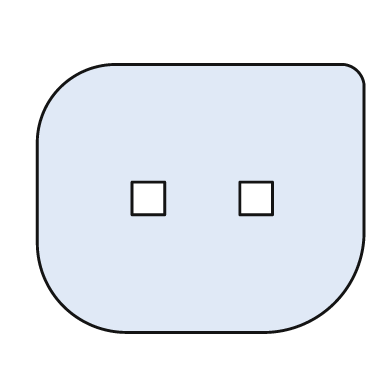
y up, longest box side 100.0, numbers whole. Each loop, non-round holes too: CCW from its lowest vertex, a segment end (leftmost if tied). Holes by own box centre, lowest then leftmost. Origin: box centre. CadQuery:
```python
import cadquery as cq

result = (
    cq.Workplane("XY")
    .moveTo(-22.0, -41.0)
    .lineTo(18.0, -41.0)
    .threePointArc((41.0, -32.0), (50.0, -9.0))
    .lineTo(50.0, 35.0)
    .threePointArc((48.0, 39.0), (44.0, 41.0))
    .lineTo(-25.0, 41.0)
    .threePointArc((-43.0, 34.0), (-50.0, 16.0))
    .lineTo(-50.0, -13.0)
    .threePointArc((-42.0, -33.0), (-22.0, -41.0))
    .close()
    .moveTo(-21.0, -5.0)
    .lineTo(-11.0, -5.0)
    .lineTo(-11.0, 5.0)
    .lineTo(-21.0, 5.0)
    .close()
    .moveTo(12.0, -5.0)
    .lineTo(22.0, -5.0)
    .lineTo(22.0, 5.0)
    .lineTo(12.0, 5.0)
    .close()
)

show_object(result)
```